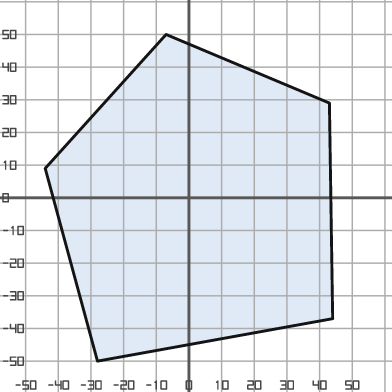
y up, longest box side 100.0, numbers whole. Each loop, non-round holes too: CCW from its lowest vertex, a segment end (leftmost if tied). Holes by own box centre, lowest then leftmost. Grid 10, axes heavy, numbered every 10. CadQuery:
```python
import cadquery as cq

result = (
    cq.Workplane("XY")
    .moveTo(-28.0, -50.0)
    .lineTo(44.0, -37.0)
    .lineTo(43.0, 29.0)
    .lineTo(-7.0, 50.0)
    .lineTo(-44.0, 9.0)
    .close()
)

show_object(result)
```